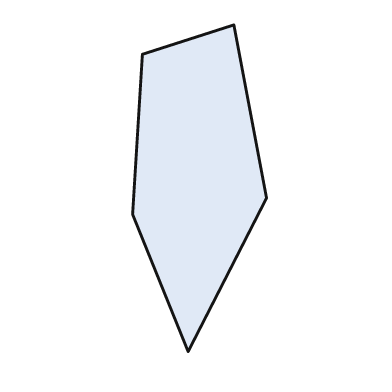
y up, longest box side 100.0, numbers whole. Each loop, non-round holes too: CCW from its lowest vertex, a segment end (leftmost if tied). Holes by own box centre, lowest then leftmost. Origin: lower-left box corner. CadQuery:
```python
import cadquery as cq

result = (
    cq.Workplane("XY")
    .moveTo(17.0, 0.0)
    .lineTo(41.0, 47.0)
    .lineTo(31.0, 100.0)
    .lineTo(3.0, 91.0)
    .lineTo(0.0, 42.0)
    .close()
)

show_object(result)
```